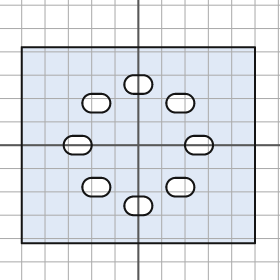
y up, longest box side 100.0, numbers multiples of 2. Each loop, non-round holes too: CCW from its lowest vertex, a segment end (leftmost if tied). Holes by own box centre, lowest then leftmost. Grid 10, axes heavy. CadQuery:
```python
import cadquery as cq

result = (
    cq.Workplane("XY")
    .moveTo(-50.0, -42.0)
    .lineTo(50.0, -42.0)
    .lineTo(50.0, 42.0)
    .lineTo(-50.0, 42.0)
    .close()
    .moveTo(-2.0, -30.0)
    .lineTo(2.0, -30.0)
    .threePointArc((6.0, -26.0), (2.0, -22.0))
    .lineTo(-2.0, -22.0)
    .threePointArc((-6.0, -26.0), (-2.0, -30.0))
    .close()
    .moveTo(-20.0, -22.0)
    .lineTo(-16.0, -22.0)
    .threePointArc((-12.0, -18.0), (-16.0, -14.0))
    .lineTo(-20.0, -14.0)
    .threePointArc((-24.0, -18.0), (-20.0, -22.0))
    .close()
    .moveTo(16.0, -22.0)
    .lineTo(20.0, -22.0)
    .threePointArc((24.0, -18.0), (20.0, -14.0))
    .lineTo(16.0, -14.0)
    .threePointArc((12.0, -18.0), (16.0, -22.0))
    .close()
    .moveTo(-28.0, -4.0)
    .lineTo(-24.0, -4.0)
    .threePointArc((-20.0, 0.0), (-24.0, 4.0))
    .lineTo(-28.0, 4.0)
    .threePointArc((-32.0, 0.0), (-28.0, -4.0))
    .close()
    .moveTo(24.0, -4.0)
    .lineTo(28.0, -4.0)
    .threePointArc((32.0, 0.0), (28.0, 4.0))
    .lineTo(24.0, 4.0)
    .threePointArc((20.0, 0.0), (24.0, -4.0))
    .close()
    .moveTo(-20.0, 14.0)
    .lineTo(-16.0, 14.0)
    .threePointArc((-12.0, 18.0), (-16.0, 22.0))
    .lineTo(-20.0, 22.0)
    .threePointArc((-24.0, 18.0), (-20.0, 14.0))
    .close()
    .moveTo(16.0, 14.0)
    .lineTo(20.0, 14.0)
    .threePointArc((24.0, 18.0), (20.0, 22.0))
    .lineTo(16.0, 22.0)
    .threePointArc((12.0, 18.0), (16.0, 14.0))
    .close()
    .moveTo(-2.0, 22.0)
    .lineTo(2.0, 22.0)
    .threePointArc((6.0, 26.0), (2.0, 30.0))
    .lineTo(-2.0, 30.0)
    .threePointArc((-6.0, 26.0), (-2.0, 22.0))
    .close()
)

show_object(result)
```